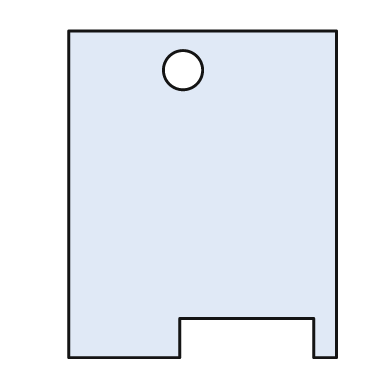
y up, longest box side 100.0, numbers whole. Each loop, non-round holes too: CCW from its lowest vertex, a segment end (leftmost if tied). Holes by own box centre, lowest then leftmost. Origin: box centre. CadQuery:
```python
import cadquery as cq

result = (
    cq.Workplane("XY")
    .moveTo(-41.0, -50.0)
    .lineTo(-7.0, -50.0)
    .lineTo(-7.0, -38.0)
    .lineTo(34.0, -38.0)
    .lineTo(34.0, -50.0)
    .lineTo(41.0, -50.0)
    .lineTo(41.0, 50.0)
    .lineTo(-41.0, 50.0)
    .close()
    .moveTo(-6.0, 38.0)
    .circle(6.0)
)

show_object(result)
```